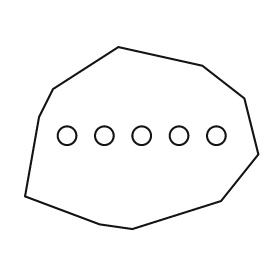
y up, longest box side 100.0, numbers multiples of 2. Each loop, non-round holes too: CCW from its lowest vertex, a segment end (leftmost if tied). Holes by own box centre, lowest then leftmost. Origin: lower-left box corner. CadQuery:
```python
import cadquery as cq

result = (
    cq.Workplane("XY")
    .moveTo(46.0, 0.0)
    .lineTo(84.0, 12.0)
    .lineTo(100.0, 32.0)
    .lineTo(94.0, 56.0)
    .lineTo(76.0, 70.0)
    .lineTo(40.0, 78.0)
    .lineTo(12.0, 60.0)
    .lineTo(6.0, 48.0)
    .lineTo(0.0, 14.0)
    .lineTo(32.0, 2.0)
    .close()
    .moveTo(18.0, 40.0)
    .circle(4.0)
    .moveTo(34.0, 40.0)
    .circle(4.0)
    .moveTo(50.0, 40.0)
    .circle(4.0)
    .moveTo(66.0, 40.0)
    .circle(4.0)
    .moveTo(82.0, 40.0)
    .circle(4.0)
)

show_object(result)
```